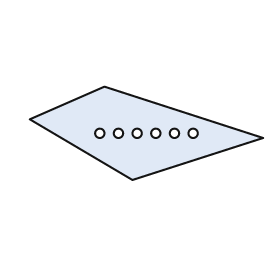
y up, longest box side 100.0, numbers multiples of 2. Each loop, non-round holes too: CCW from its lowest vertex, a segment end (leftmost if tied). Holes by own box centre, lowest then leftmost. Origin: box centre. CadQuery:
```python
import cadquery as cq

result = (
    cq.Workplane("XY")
    .moveTo(-6.0, -20.0)
    .lineTo(50.0, -2.0)
    .lineTo(-18.0, 20.0)
    .lineTo(-50.0, 6.0)
    .close()
    .moveTo(-20.0, 0.0)
    .circle(2.0)
    .moveTo(-12.0, 0.0)
    .circle(2.0)
    .moveTo(-4.0, 0.0)
    .circle(2.0)
    .moveTo(4.0, 0.0)
    .circle(2.0)
    .moveTo(12.0, 0.0)
    .circle(2.0)
    .moveTo(20.0, 0.0)
    .circle(2.0)
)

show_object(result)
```